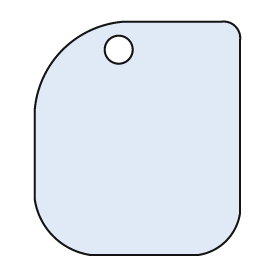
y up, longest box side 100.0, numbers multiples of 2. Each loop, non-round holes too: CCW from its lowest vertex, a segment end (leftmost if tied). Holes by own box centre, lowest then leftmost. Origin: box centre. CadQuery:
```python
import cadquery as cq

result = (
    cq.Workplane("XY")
    .moveTo(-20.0, -50.0)
    .lineTo(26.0, -50.0)
    .threePointArc((38.0, -44.0), (44.0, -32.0))
    .lineTo(44.0, 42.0)
    .threePointArc((42.0, 48.0), (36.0, 50.0))
    .lineTo(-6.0, 50.0)
    .threePointArc((-32.0, 38.0), (-44.0, 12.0))
    .lineTo(-44.0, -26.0)
    .threePointArc((-36.0, -42.0), (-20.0, -50.0))
    .close()
    .moveTo(-8.0, 38.0)
    .circle(6.0)
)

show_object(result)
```